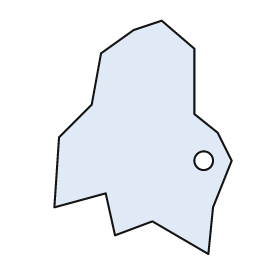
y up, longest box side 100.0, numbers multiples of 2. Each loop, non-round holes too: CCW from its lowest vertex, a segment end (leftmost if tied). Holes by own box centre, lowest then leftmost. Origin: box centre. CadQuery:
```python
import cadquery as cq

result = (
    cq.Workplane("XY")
    .moveTo(28.0, -50.0)
    .lineTo(30.0, -30.0)
    .lineTo(38.0, -10.0)
    .lineTo(32.0, 2.0)
    .lineTo(22.0, 10.0)
    .lineTo(22.0, 38.0)
    .lineTo(8.0, 50.0)
    .lineTo(-4.0, 46.0)
    .lineTo(-18.0, 36.0)
    .lineTo(-22.0, 14.0)
    .lineTo(-36.0, 0.0)
    .lineTo(-38.0, -30.0)
    .lineTo(-16.0, -24.0)
    .lineTo(-12.0, -42.0)
    .lineTo(4.0, -36.0)
    .close()
    .moveTo(26.0, -10.0)
    .circle(4.0)
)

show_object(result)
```